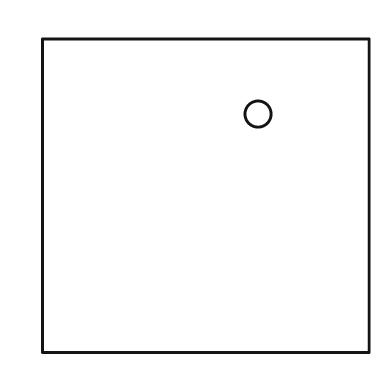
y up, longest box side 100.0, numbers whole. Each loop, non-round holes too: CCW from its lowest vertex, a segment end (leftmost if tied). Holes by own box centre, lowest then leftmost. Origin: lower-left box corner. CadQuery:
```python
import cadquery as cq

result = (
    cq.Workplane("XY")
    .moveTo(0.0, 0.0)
    .lineTo(100.0, 0.0)
    .lineTo(100.0, 96.0)
    .lineTo(0.0, 96.0)
    .close()
    .moveTo(66.0, 73.0)
    .circle(4.0)
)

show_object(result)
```